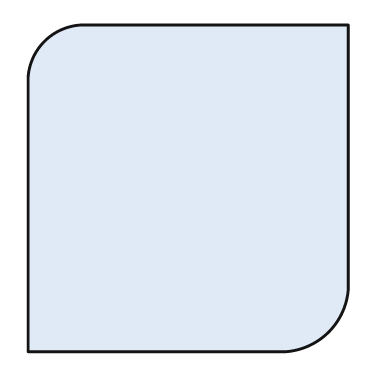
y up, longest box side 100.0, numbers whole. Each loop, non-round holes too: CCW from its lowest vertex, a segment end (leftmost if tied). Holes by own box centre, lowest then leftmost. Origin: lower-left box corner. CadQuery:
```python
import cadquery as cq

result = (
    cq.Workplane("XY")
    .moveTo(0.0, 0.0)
    .lineTo(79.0, 0.0)
    .threePointArc((92.0, 6.0), (98.0, 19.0))
    .lineTo(98.0, 100.0)
    .lineTo(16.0, 100.0)
    .threePointArc((5.0, 95.0), (0.0, 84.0))
    .close()
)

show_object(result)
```